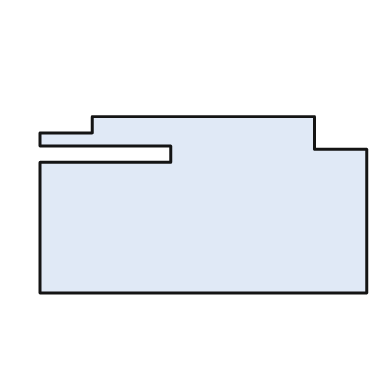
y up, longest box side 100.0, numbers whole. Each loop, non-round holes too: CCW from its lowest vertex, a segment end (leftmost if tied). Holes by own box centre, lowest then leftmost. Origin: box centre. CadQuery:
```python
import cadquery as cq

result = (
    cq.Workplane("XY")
    .moveTo(-50.0, -27.0)
    .lineTo(50.0, -27.0)
    .lineTo(50.0, 17.0)
    .lineTo(34.0, 17.0)
    .lineTo(34.0, 27.0)
    .lineTo(-34.0, 27.0)
    .lineTo(-34.0, 22.0)
    .lineTo(-50.0, 22.0)
    .lineTo(-50.0, 18.0)
    .lineTo(-10.0, 18.0)
    .lineTo(-10.0, 13.0)
    .lineTo(-50.0, 13.0)
    .close()
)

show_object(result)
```